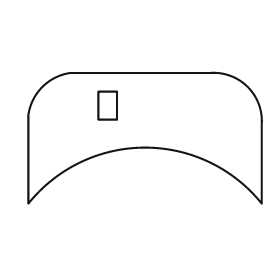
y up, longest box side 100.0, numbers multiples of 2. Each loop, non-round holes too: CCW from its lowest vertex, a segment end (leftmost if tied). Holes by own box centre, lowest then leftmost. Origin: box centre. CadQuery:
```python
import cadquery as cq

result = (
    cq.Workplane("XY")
    .moveTo(-50.0, -28.0)
    .threePointArc((0.0, -4.0), (50.0, -28.0))
    .lineTo(50.0, 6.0)
    .threePointArc((44.0, 22.0), (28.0, 28.0))
    .lineTo(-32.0, 28.0)
    .threePointArc((-44.0, 22.0), (-50.0, 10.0))
    .close()
    .moveTo(-20.0, 8.0)
    .lineTo(-12.0, 8.0)
    .lineTo(-12.0, 20.0)
    .lineTo(-20.0, 20.0)
    .close()
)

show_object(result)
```